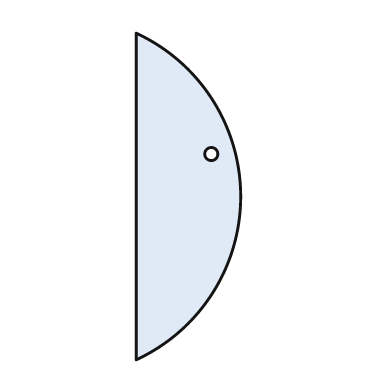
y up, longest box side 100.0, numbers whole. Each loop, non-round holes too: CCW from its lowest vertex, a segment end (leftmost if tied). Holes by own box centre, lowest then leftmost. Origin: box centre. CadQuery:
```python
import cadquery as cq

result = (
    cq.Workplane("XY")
    .moveTo(-16.0, -50.0)
    .threePointArc((16.0, 0.0), (-16.0, 50.0))
    .close()
    .moveTo(7.0, 13.0)
    .circle(2.0)
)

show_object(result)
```